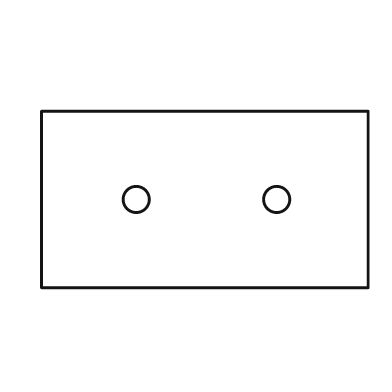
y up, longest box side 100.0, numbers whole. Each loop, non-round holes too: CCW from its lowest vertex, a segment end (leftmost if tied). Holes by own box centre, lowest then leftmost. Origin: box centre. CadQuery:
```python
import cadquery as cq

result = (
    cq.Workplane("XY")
    .moveTo(-50.0, -27.0)
    .lineTo(50.0, -27.0)
    .lineTo(50.0, 27.0)
    .lineTo(-50.0, 27.0)
    .close()
    .moveTo(-21.0, 0.0)
    .circle(4.0)
    .moveTo(22.0, 0.0)
    .circle(4.0)
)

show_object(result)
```